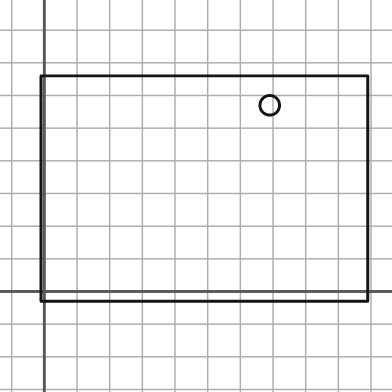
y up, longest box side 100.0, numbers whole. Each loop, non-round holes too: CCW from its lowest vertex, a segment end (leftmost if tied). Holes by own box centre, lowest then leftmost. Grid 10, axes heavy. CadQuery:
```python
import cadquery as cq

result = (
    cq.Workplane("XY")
    .moveTo(-1.0, -3.0)
    .lineTo(99.0, -3.0)
    .lineTo(99.0, 66.0)
    .lineTo(-1.0, 66.0)
    .close()
    .moveTo(69.0, 57.0)
    .circle(3.0)
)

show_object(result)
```